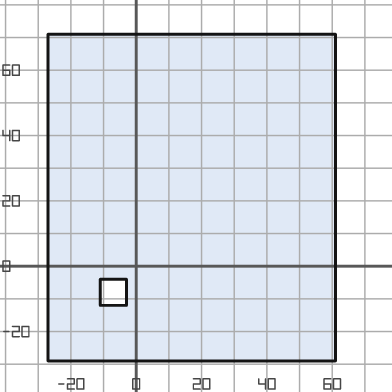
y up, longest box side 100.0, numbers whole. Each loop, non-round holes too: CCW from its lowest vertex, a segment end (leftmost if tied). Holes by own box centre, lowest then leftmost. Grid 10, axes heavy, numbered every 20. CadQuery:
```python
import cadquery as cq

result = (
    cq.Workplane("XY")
    .moveTo(-27.0, -29.0)
    .lineTo(61.0, -29.0)
    .lineTo(61.0, 71.0)
    .lineTo(-27.0, 71.0)
    .close()
    .moveTo(-11.0, -12.0)
    .lineTo(-3.0, -12.0)
    .lineTo(-3.0, -4.0)
    .lineTo(-11.0, -4.0)
    .close()
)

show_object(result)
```